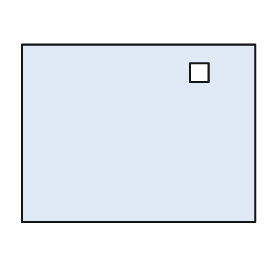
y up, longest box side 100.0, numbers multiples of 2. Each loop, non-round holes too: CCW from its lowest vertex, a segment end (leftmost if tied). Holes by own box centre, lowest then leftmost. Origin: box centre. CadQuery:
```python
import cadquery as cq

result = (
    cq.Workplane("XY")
    .moveTo(-50.0, -38.0)
    .lineTo(50.0, -38.0)
    .lineTo(50.0, 38.0)
    .lineTo(-50.0, 38.0)
    .close()
    .moveTo(22.0, 22.0)
    .lineTo(30.0, 22.0)
    .lineTo(30.0, 30.0)
    .lineTo(22.0, 30.0)
    .close()
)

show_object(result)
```